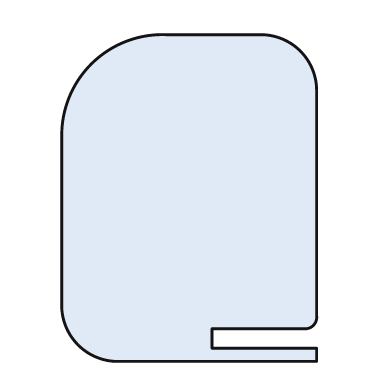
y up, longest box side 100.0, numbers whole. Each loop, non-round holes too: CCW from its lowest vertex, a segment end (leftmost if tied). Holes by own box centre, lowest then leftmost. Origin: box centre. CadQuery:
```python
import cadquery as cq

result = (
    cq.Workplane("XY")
    .moveTo(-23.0, -50.0)
    .lineTo(39.0, -50.0)
    .lineTo(39.0, -46.0)
    .lineTo(7.0, -46.0)
    .lineTo(7.0, -40.0)
    .lineTo(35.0, -40.0)
    .threePointArc((38.0, -39.0), (39.0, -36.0))
    .lineTo(39.0, 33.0)
    .threePointArc((34.0, 45.0), (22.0, 50.0))
    .lineTo(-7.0, 50.0)
    .threePointArc((-30.0, 41.0), (-39.0, 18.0))
    .lineTo(-39.0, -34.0)
    .threePointArc((-34.0, -45.0), (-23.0, -50.0))
    .close()
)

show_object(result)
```